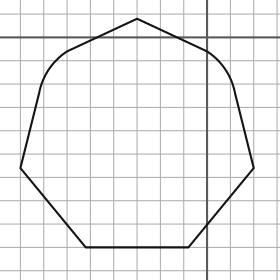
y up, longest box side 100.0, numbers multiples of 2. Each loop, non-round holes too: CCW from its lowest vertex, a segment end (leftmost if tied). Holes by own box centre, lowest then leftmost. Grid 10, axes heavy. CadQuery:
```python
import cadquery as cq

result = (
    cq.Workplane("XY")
    .moveTo(-52.0, -90.0)
    .lineTo(-8.0, -90.0)
    .lineTo(20.0, -56.0)
    .lineTo(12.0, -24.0)
    .threePointArc((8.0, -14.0), (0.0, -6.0))
    .lineTo(-30.0, 8.0)
    .lineTo(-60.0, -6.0)
    .threePointArc((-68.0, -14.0), (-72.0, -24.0))
    .lineTo(-80.0, -56.0)
    .close()
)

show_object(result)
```